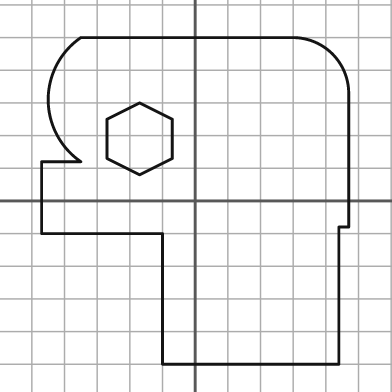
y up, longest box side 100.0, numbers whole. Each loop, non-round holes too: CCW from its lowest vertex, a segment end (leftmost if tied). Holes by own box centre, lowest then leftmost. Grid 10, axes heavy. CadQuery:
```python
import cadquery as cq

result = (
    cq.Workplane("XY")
    .moveTo(-10.0, -50.0)
    .lineTo(44.0, -50.0)
    .lineTo(44.0, -8.0)
    .lineTo(47.0, -8.0)
    .lineTo(47.0, 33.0)
    .threePointArc((42.0, 45.0), (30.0, 50.0))
    .lineTo(-35.0, 50.0)
    .threePointArc((-45.0, 31.0), (-35.0, 12.0))
    .lineTo(-47.0, 12.0)
    .lineTo(-47.0, -10.0)
    .lineTo(-10.0, -10.0)
    .close()
    .moveTo(-17.0, 8.0)
    .lineTo(-7.0, 13.0)
    .lineTo(-7.0, 25.0)
    .lineTo(-17.0, 30.0)
    .lineTo(-27.0, 25.0)
    .lineTo(-27.0, 13.0)
    .close()
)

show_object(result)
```